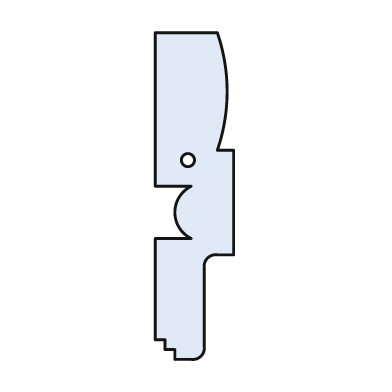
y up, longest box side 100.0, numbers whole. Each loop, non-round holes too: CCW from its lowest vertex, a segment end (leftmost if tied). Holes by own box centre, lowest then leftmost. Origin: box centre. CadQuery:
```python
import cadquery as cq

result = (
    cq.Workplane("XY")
    .moveTo(-6.0, -50.0)
    .lineTo(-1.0, -50.0)
    .threePointArc((2.0, -49.0), (3.0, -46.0))
    .lineTo(3.0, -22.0)
    .threePointArc((4.0, -19.0), (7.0, -18.0))
    .lineTo(12.0, -18.0)
    .lineTo(12.0, 14.0)
    .lineTo(7.0, 14.0)
    .threePointArc((10.0, 32.0), (7.0, 50.0))
    .lineTo(-12.0, 50.0)
    .lineTo(-12.0, 3.0)
    .lineTo(-1.0, 3.0)
    .threePointArc((-6.0, -5.0), (-1.0, -13.0))
    .lineTo(-12.0, -13.0)
    .lineTo(-12.0, -44.0)
    .lineTo(-9.0, -44.0)
    .lineTo(-9.0, -47.0)
    .lineTo(-6.0, -47.0)
    .close()
    .moveTo(-2.0, 11.0)
    .circle(2.0)
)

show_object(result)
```